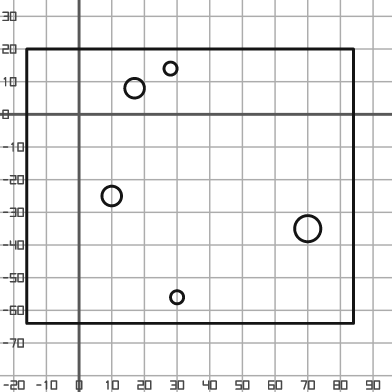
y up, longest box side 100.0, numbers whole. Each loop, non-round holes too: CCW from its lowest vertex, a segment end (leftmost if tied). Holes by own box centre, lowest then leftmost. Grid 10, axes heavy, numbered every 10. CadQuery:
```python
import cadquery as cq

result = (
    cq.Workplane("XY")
    .moveTo(-16.0, -64.0)
    .lineTo(84.0, -64.0)
    .lineTo(84.0, 20.0)
    .lineTo(-16.0, 20.0)
    .close()
    .moveTo(30.0, -56.0)
    .circle(2.0)
    .moveTo(70.0, -35.0)
    .circle(4.0)
    .moveTo(10.0, -25.0)
    .circle(3.0)
    .moveTo(17.0, 8.0)
    .circle(3.0)
    .moveTo(28.0, 14.0)
    .circle(2.0)
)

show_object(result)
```